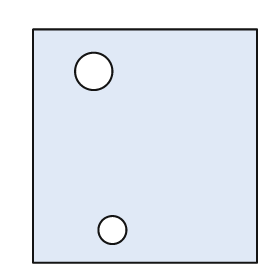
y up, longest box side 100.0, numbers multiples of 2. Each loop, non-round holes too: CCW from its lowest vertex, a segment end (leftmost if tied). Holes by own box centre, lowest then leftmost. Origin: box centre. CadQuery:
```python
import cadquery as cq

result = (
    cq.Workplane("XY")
    .moveTo(-48.0, -50.0)
    .lineTo(48.0, -50.0)
    .lineTo(48.0, 50.0)
    .lineTo(-48.0, 50.0)
    .close()
    .moveTo(-14.0, -36.0)
    .circle(6.0)
    .moveTo(-22.0, 32.0)
    .circle(8.0)
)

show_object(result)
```